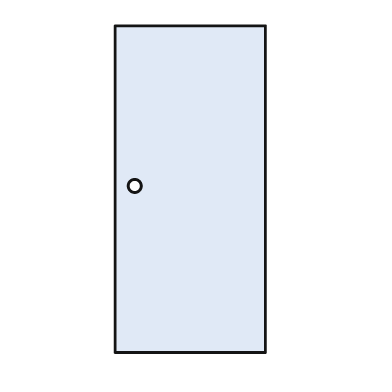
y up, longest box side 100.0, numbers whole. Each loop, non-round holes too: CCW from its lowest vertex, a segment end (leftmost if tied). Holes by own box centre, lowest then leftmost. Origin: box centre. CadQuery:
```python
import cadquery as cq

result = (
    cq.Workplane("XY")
    .moveTo(-23.0, -50.0)
    .lineTo(23.0, -50.0)
    .lineTo(23.0, 50.0)
    .lineTo(-23.0, 50.0)
    .close()
    .moveTo(-17.0, 1.0)
    .circle(2.0)
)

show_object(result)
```